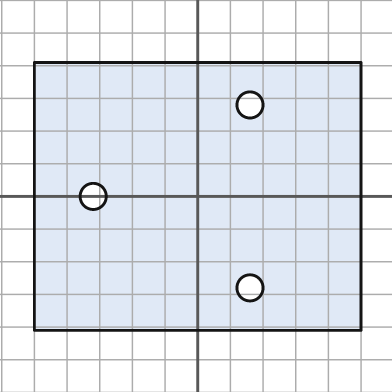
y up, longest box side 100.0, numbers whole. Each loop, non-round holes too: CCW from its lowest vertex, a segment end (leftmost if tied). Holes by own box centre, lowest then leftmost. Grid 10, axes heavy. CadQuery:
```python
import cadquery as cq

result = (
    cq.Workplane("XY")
    .moveTo(-50.0, -41.0)
    .lineTo(50.0, -41.0)
    .lineTo(50.0, 41.0)
    .lineTo(-50.0, 41.0)
    .close()
    .moveTo(16.0, -28.0)
    .circle(4.0)
    .moveTo(-32.0, 0.0)
    .circle(4.0)
    .moveTo(16.0, 28.0)
    .circle(4.0)
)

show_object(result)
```